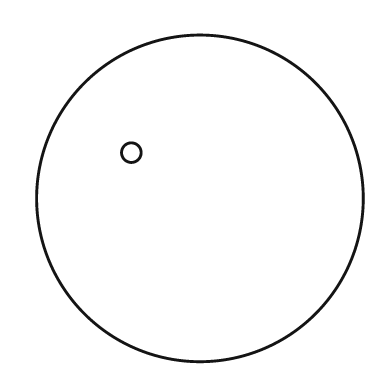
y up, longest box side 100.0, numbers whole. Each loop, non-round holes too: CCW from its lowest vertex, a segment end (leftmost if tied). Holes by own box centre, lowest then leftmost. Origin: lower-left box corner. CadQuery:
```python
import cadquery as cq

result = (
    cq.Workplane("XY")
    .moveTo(50.0, 50.0)
    .circle(50.0)
    .moveTo(29.0, 64.0)
    .circle(3.0)
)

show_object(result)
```